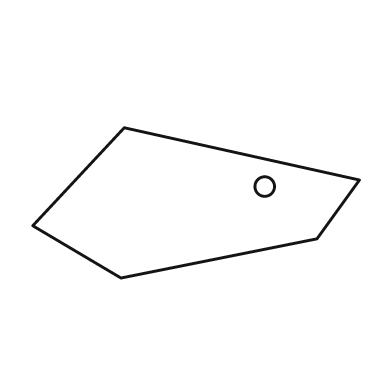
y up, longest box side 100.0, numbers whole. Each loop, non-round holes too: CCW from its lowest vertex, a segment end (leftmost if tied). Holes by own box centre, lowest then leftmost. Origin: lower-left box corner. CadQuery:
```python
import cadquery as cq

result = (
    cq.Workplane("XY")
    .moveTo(27.0, 0.0)
    .lineTo(87.0, 12.0)
    .lineTo(100.0, 30.0)
    .lineTo(28.0, 46.0)
    .lineTo(0.0, 16.0)
    .close()
    .moveTo(71.0, 28.0)
    .circle(3.0)
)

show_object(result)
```